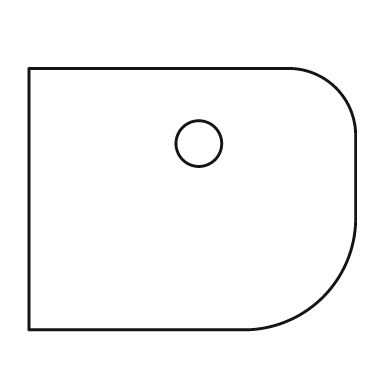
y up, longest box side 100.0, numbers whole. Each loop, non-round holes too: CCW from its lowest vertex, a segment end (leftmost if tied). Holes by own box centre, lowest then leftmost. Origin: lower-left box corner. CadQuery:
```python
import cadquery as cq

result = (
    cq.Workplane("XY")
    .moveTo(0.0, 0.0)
    .lineTo(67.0, 0.0)
    .threePointArc((90.0, 10.0), (100.0, 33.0))
    .lineTo(100.0, 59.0)
    .threePointArc((94.0, 74.0), (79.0, 80.0))
    .lineTo(0.0, 80.0)
    .close()
    .moveTo(52.0, 57.0)
    .circle(7.0)
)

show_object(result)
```